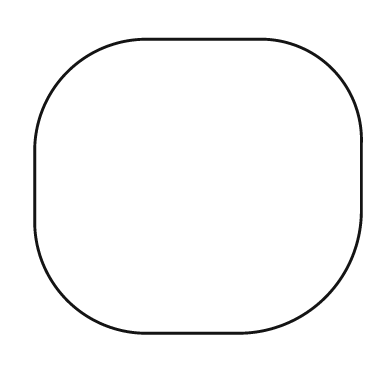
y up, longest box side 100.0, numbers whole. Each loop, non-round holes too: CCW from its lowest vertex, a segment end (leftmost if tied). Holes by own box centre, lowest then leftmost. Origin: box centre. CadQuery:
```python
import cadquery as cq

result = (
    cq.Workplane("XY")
    .moveTo(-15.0, -45.0)
    .lineTo(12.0, -45.0)
    .threePointArc((39.0, -34.0), (50.0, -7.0))
    .lineTo(50.0, 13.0)
    .threePointArc((41.0, 36.0), (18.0, 45.0))
    .lineTo(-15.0, 45.0)
    .threePointArc((-40.0, 35.0), (-50.0, 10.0))
    .lineTo(-50.0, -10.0)
    .threePointArc((-40.0, -35.0), (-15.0, -45.0))
    .close()
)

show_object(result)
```